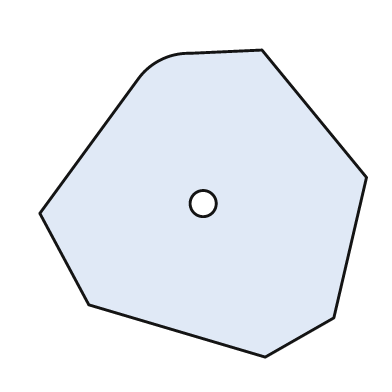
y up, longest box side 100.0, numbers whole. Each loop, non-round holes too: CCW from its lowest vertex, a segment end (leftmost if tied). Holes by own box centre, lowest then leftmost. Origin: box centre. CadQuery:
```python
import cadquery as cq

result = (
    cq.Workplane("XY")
    .moveTo(19.0, -47.0)
    .lineTo(40.0, -35.0)
    .lineTo(50.0, 8.0)
    .lineTo(18.0, 47.0)
    .lineTo(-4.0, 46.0)
    .threePointArc((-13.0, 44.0), (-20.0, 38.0))
    .lineTo(-50.0, -3.0)
    .lineTo(-35.0, -31.0)
    .close()
    .moveTo(0.0, 0.0)
    .circle(4.0)
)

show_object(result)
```